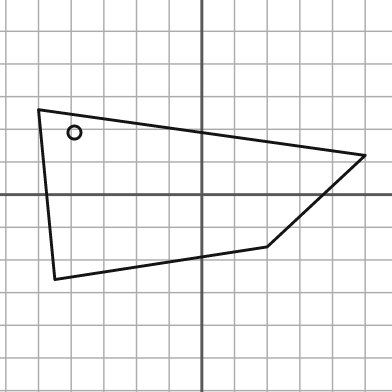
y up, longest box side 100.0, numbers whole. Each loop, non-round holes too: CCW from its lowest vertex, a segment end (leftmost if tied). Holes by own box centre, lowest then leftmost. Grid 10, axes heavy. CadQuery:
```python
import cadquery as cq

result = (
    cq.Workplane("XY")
    .moveTo(-45.0, -26.0)
    .lineTo(20.0, -16.0)
    .lineTo(50.0, 12.0)
    .lineTo(-50.0, 26.0)
    .close()
    .moveTo(-39.0, 19.0)
    .circle(2.0)
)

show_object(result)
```